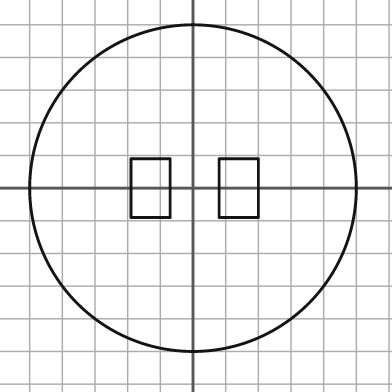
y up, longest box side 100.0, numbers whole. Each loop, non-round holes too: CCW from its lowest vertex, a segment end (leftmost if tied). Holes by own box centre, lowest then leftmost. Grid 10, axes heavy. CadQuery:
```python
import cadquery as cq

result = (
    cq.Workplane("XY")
    .moveTo(0.0, 0.0)
    .circle(50.0)
    .moveTo(-19.0, -9.0)
    .lineTo(-7.0, -9.0)
    .lineTo(-7.0, 9.0)
    .lineTo(-19.0, 9.0)
    .close()
    .moveTo(8.0, -9.0)
    .lineTo(20.0, -9.0)
    .lineTo(20.0, 9.0)
    .lineTo(8.0, 9.0)
    .close()
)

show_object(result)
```